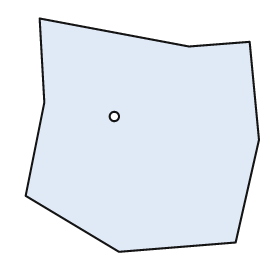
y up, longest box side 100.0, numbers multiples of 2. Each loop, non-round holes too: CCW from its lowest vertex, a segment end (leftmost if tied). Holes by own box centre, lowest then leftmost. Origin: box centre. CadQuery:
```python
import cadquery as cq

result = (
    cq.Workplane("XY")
    .moveTo(-10.0, -50.0)
    .lineTo(40.0, -46.0)
    .lineTo(50.0, -2.0)
    .lineTo(46.0, 40.0)
    .lineTo(20.0, 38.0)
    .lineTo(-44.0, 50.0)
    .lineTo(-42.0, 14.0)
    .lineTo(-50.0, -26.0)
    .close()
    .moveTo(-12.0, 8.0)
    .circle(2.0)
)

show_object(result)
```